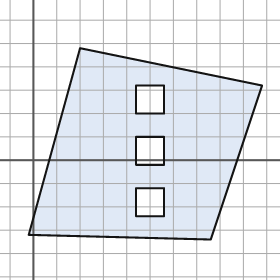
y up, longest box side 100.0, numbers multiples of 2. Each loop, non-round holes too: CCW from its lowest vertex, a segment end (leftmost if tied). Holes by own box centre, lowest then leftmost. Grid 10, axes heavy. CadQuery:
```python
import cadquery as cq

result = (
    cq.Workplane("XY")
    .moveTo(76.0, -34.0)
    .lineTo(98.0, 32.0)
    .lineTo(20.0, 48.0)
    .lineTo(-2.0, -32.0)
    .close()
    .moveTo(44.0, -24.0)
    .lineTo(56.0, -24.0)
    .lineTo(56.0, -12.0)
    .lineTo(44.0, -12.0)
    .close()
    .moveTo(44.0, -2.0)
    .lineTo(56.0, -2.0)
    .lineTo(56.0, 10.0)
    .lineTo(44.0, 10.0)
    .close()
    .moveTo(44.0, 20.0)
    .lineTo(56.0, 20.0)
    .lineTo(56.0, 32.0)
    .lineTo(44.0, 32.0)
    .close()
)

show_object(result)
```